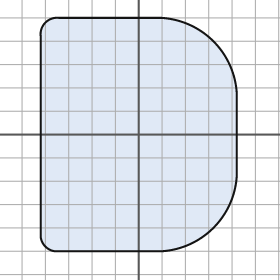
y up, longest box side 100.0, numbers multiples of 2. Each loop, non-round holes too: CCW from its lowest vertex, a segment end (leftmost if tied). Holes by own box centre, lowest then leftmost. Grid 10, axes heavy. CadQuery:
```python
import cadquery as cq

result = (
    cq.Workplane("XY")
    .moveTo(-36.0, -50.0)
    .lineTo(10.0, -50.0)
    .threePointArc((32.0, -40.0), (42.0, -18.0))
    .lineTo(42.0, 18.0)
    .threePointArc((32.0, 40.0), (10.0, 50.0))
    .lineTo(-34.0, 50.0)
    .threePointArc((-40.0, 48.0), (-42.0, 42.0))
    .lineTo(-42.0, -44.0)
    .threePointArc((-40.0, -48.0), (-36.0, -50.0))
    .close()
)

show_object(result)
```